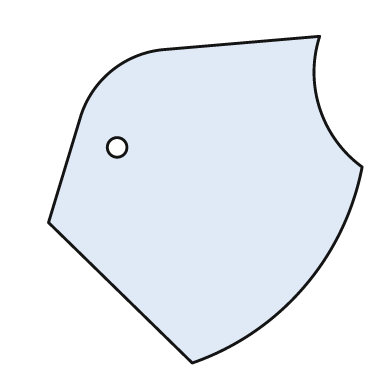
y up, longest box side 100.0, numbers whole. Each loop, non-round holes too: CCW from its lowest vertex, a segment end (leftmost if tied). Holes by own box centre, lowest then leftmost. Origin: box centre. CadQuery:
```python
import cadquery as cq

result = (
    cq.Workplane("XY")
    .moveTo(-4.0, -50.0)
    .threePointArc((30.0, -27.0), (48.0, 10.0))
    .threePointArc((35.0, 28.0), (35.0, 50.0))
    .lineTo(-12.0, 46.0)
    .threePointArc((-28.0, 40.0), (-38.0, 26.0))
    .lineTo(-48.0, -7.0)
    .close()
    .moveTo(-27.0, 16.0)
    .circle(3.0)
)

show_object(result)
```